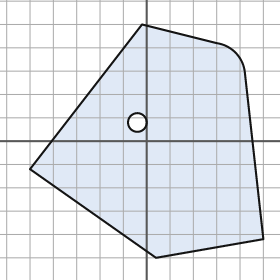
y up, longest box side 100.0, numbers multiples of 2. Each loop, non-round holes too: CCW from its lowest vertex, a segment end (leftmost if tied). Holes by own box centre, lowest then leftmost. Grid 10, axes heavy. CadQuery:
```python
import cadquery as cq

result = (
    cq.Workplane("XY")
    .moveTo(4.0, -50.0)
    .lineTo(50.0, -42.0)
    .lineTo(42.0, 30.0)
    .threePointArc((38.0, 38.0), (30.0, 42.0))
    .lineTo(-2.0, 50.0)
    .lineTo(-50.0, -12.0)
    .close()
    .moveTo(-4.0, 8.0)
    .circle(4.0)
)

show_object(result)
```